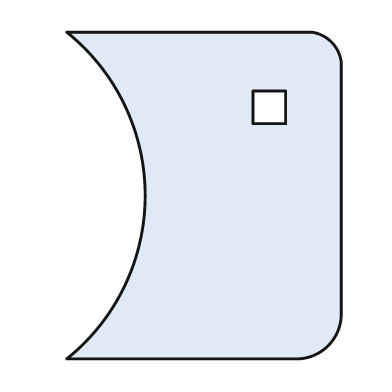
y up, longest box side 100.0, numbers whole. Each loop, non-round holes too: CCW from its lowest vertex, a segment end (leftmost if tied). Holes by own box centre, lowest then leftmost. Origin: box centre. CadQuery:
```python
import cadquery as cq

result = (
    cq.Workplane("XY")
    .moveTo(-42.0, -50.0)
    .lineTo(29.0, -50.0)
    .threePointArc((38.0, -46.0), (42.0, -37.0))
    .lineTo(42.0, 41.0)
    .threePointArc((39.0, 47.0), (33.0, 50.0))
    .lineTo(-42.0, 50.0)
    .threePointArc((-18.0, 0.0), (-42.0, -50.0))
    .close()
    .moveTo(15.0, 22.0)
    .lineTo(25.0, 22.0)
    .lineTo(25.0, 32.0)
    .lineTo(15.0, 32.0)
    .close()
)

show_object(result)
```